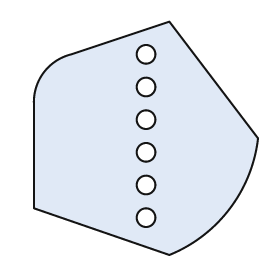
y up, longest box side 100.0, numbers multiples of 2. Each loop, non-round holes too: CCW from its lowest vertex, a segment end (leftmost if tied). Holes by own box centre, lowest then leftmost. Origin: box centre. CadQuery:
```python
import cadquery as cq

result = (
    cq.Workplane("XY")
    .moveTo(10.0, -50.0)
    .threePointArc((36.0, -30.0), (48.0, 0.0))
    .lineTo(10.0, 50.0)
    .lineTo(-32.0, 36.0)
    .threePointArc((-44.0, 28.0), (-48.0, 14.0))
    .lineTo(-48.0, -30.0)
    .close()
    .moveTo(0.0, -34.0)
    .circle(4.0)
    .moveTo(0.0, -20.0)
    .circle(4.0)
    .moveTo(0.0, -6.0)
    .circle(4.0)
    .moveTo(0.0, 8.0)
    .circle(4.0)
    .moveTo(0.0, 22.0)
    .circle(4.0)
    .moveTo(0.0, 36.0)
    .circle(4.0)
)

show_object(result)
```